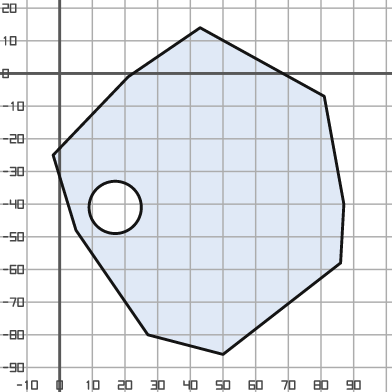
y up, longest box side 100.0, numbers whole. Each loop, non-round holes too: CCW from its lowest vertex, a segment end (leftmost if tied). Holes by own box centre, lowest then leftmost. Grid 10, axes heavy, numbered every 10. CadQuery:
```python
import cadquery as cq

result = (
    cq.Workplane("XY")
    .moveTo(50.0, -86.0)
    .lineTo(86.0, -58.0)
    .lineTo(87.0, -40.0)
    .lineTo(81.0, -7.0)
    .lineTo(43.0, 14.0)
    .lineTo(21.0, -1.0)
    .lineTo(-2.0, -25.0)
    .lineTo(5.0, -48.0)
    .lineTo(27.0, -80.0)
    .close()
    .moveTo(17.0, -41.0)
    .circle(8.0)
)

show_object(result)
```